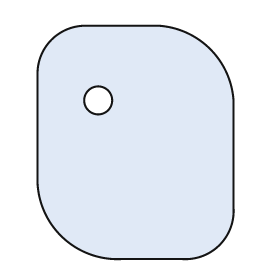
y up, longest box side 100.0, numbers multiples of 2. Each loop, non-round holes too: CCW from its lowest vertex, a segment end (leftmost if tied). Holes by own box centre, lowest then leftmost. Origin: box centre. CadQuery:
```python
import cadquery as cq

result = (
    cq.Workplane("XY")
    .moveTo(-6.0, -50.0)
    .lineTo(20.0, -50.0)
    .threePointArc((36.0, -44.0), (42.0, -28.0))
    .lineTo(42.0, 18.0)
    .threePointArc((32.0, 40.0), (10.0, 50.0))
    .lineTo(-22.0, 50.0)
    .threePointArc((-36.0, 44.0), (-42.0, 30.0))
    .lineTo(-42.0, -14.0)
    .threePointArc((-32.0, -40.0), (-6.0, -50.0))
    .close()
    .moveTo(-16.0, 18.0)
    .circle(6.0)
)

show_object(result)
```